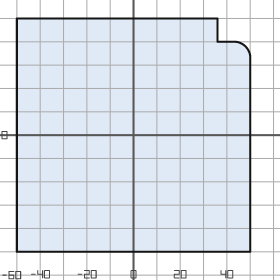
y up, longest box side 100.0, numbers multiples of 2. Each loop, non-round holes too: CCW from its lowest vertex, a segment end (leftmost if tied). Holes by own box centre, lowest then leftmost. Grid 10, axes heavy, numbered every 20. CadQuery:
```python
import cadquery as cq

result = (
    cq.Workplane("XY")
    .moveTo(-50.0, -50.0)
    .lineTo(50.0, -50.0)
    .lineTo(50.0, 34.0)
    .threePointArc((48.0, 38.0), (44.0, 40.0))
    .lineTo(36.0, 40.0)
    .lineTo(36.0, 50.0)
    .lineTo(-50.0, 50.0)
    .close()
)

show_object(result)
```